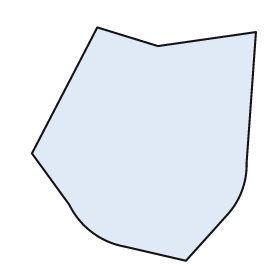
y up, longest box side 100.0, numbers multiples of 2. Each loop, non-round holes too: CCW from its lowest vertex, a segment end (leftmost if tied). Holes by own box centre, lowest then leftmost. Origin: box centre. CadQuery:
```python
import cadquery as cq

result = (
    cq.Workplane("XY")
    .moveTo(18.0, -50.0)
    .lineTo(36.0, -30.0)
    .threePointArc((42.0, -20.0), (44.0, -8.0))
    .lineTo(48.0, 48.0)
    .lineTo(6.0, 42.0)
    .lineTo(-20.0, 50.0)
    .lineTo(-48.0, -4.0)
    .lineTo(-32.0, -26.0)
    .threePointArc((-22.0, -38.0), (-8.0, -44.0))
    .close()
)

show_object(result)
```